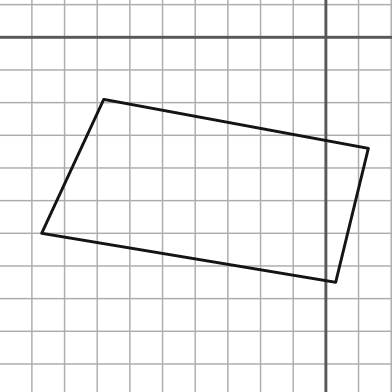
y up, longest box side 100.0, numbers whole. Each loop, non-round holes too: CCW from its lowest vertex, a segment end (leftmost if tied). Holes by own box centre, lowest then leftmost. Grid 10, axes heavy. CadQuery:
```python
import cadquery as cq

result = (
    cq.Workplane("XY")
    .moveTo(3.0, -75.0)
    .lineTo(13.0, -34.0)
    .lineTo(-68.0, -19.0)
    .lineTo(-87.0, -60.0)
    .close()
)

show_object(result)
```